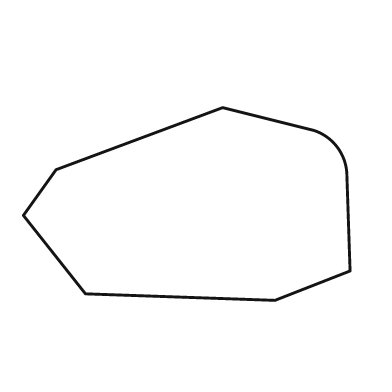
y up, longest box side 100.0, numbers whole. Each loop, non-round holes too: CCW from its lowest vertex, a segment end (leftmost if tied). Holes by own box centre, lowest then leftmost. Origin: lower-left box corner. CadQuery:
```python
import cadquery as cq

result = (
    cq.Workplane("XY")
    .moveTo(77.0, 0.0)
    .lineTo(100.0, 9.0)
    .lineTo(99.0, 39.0)
    .threePointArc((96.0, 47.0), (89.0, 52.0))
    .lineTo(61.0, 59.0)
    .lineTo(10.0, 40.0)
    .lineTo(0.0, 26.0)
    .lineTo(19.0, 2.0)
    .close()
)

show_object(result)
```